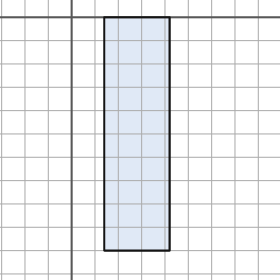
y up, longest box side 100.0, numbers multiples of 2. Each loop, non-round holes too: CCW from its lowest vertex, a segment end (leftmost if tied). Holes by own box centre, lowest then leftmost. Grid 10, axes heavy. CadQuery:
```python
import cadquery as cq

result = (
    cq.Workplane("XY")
    .moveTo(14.0, -100.0)
    .lineTo(42.0, -100.0)
    .lineTo(42.0, 0.0)
    .lineTo(14.0, 0.0)
    .close()
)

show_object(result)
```